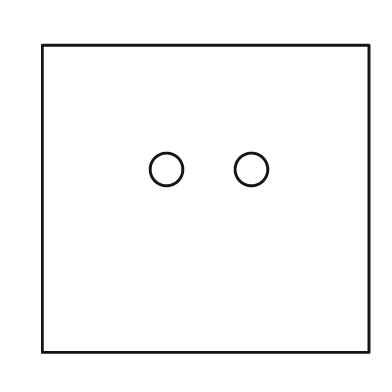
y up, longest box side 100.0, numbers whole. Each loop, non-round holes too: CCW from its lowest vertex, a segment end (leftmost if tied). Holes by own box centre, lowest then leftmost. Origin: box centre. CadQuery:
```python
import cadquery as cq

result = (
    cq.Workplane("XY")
    .moveTo(-50.0, -47.0)
    .lineTo(50.0, -47.0)
    .lineTo(50.0, 47.0)
    .lineTo(-50.0, 47.0)
    .close()
    .moveTo(-12.0, 9.0)
    .circle(5.0)
    .moveTo(14.0, 9.0)
    .circle(5.0)
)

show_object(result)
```